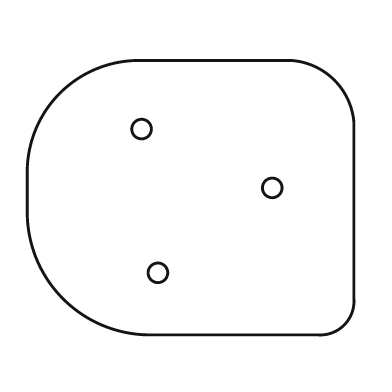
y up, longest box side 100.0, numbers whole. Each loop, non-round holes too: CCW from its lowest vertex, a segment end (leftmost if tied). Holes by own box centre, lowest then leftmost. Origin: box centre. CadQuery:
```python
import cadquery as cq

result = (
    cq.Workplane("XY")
    .moveTo(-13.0, -42.0)
    .lineTo(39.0, -42.0)
    .threePointArc((47.0, -39.0), (50.0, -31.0))
    .lineTo(50.0, 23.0)
    .threePointArc((44.0, 36.0), (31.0, 42.0))
    .lineTo(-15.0, 42.0)
    .threePointArc((-40.0, 32.0), (-50.0, 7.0))
    .lineTo(-50.0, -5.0)
    .threePointArc((-39.0, -31.0), (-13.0, -42.0))
    .close()
    .moveTo(-10.0, -23.0)
    .circle(3.0)
    .moveTo(25.0, 3.0)
    .circle(3.0)
    .moveTo(-15.0, 21.0)
    .circle(3.0)
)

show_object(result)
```